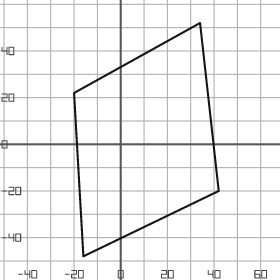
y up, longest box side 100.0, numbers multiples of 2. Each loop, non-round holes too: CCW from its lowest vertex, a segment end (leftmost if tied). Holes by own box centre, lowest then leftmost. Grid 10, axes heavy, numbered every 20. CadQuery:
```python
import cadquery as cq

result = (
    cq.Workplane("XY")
    .moveTo(-16.0, -48.0)
    .lineTo(42.0, -20.0)
    .lineTo(34.0, 52.0)
    .lineTo(-20.0, 22.0)
    .close()
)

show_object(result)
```